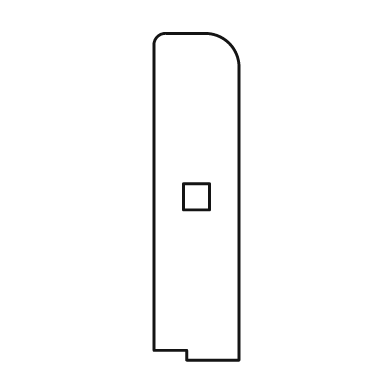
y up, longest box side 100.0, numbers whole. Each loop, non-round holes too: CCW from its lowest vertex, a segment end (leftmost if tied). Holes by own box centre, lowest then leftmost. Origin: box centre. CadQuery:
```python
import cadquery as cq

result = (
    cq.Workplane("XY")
    .moveTo(-3.0, -50.0)
    .lineTo(13.0, -50.0)
    .lineTo(13.0, 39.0)
    .threePointArc((10.0, 47.0), (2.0, 50.0))
    .lineTo(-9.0, 50.0)
    .threePointArc((-12.0, 49.0), (-13.0, 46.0))
    .lineTo(-13.0, -47.0)
    .lineTo(-3.0, -47.0)
    .close()
    .moveTo(-4.0, -4.0)
    .lineTo(4.0, -4.0)
    .lineTo(4.0, 4.0)
    .lineTo(-4.0, 4.0)
    .close()
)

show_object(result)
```